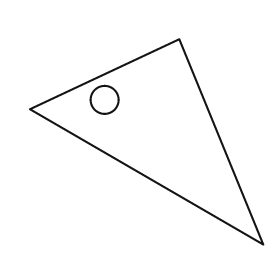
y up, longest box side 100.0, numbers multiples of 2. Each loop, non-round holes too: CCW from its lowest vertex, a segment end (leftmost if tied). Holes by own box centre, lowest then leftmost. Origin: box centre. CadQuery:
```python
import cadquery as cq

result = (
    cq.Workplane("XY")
    .moveTo(50.0, -44.0)
    .lineTo(14.0, 44.0)
    .lineTo(-50.0, 14.0)
    .close()
    .moveTo(-18.0, 18.0)
    .circle(6.0)
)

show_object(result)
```